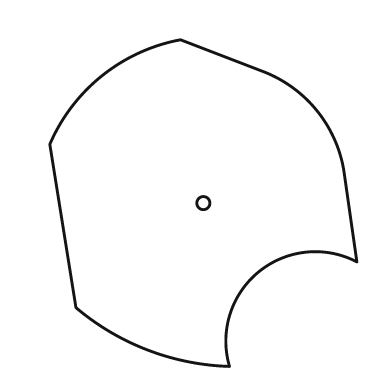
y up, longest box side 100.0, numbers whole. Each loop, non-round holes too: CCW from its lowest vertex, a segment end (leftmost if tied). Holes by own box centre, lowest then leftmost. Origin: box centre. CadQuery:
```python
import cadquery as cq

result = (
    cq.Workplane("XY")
    .moveTo(8.0, -50.0)
    .threePointArc((17.0, -21.0), (47.0, -18.0))
    .lineTo(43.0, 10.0)
    .threePointArc((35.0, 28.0), (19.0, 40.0))
    .lineTo(-7.0, 50.0)
    .threePointArc((-31.0, 39.0), (-47.0, 18.0))
    .lineTo(-39.0, -32.0)
    .threePointArc((-17.0, -45.0), (8.0, -50.0))
    .close()
    .moveTo(0.0, 0.0)
    .circle(2.0)
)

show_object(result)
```